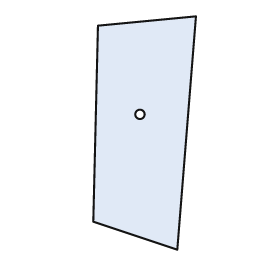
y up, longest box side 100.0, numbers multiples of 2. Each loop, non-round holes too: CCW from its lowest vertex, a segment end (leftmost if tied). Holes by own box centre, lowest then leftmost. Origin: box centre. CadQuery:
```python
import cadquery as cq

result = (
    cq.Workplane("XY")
    .moveTo(14.0, -50.0)
    .lineTo(22.0, 50.0)
    .lineTo(-20.0, 46.0)
    .lineTo(-22.0, -38.0)
    .close()
    .moveTo(-2.0, 8.0)
    .circle(2.0)
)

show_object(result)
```